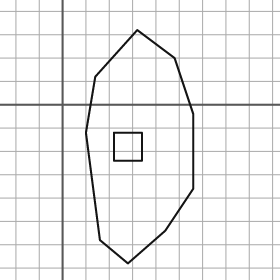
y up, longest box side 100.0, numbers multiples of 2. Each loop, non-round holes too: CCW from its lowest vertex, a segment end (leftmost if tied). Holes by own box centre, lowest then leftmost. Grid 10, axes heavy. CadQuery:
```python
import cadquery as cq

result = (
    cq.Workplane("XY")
    .moveTo(28.0, -68.0)
    .lineTo(44.0, -54.0)
    .lineTo(56.0, -36.0)
    .lineTo(56.0, -4.0)
    .lineTo(48.0, 20.0)
    .lineTo(32.0, 32.0)
    .lineTo(14.0, 12.0)
    .lineTo(10.0, -12.0)
    .lineTo(16.0, -58.0)
    .close()
    .moveTo(22.0, -24.0)
    .lineTo(34.0, -24.0)
    .lineTo(34.0, -12.0)
    .lineTo(22.0, -12.0)
    .close()
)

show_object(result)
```